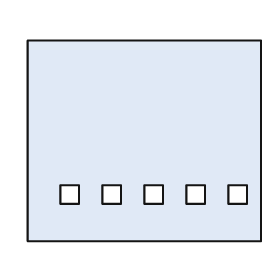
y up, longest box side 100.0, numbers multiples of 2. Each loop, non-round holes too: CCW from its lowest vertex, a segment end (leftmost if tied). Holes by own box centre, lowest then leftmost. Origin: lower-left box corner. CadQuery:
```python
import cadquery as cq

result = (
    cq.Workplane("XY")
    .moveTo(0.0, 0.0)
    .lineTo(100.0, 0.0)
    .lineTo(100.0, 86.0)
    .lineTo(0.0, 86.0)
    .close()
    .moveTo(14.0, 16.0)
    .lineTo(22.0, 16.0)
    .lineTo(22.0, 24.0)
    .lineTo(14.0, 24.0)
    .close()
    .moveTo(32.0, 16.0)
    .lineTo(40.0, 16.0)
    .lineTo(40.0, 24.0)
    .lineTo(32.0, 24.0)
    .close()
    .moveTo(50.0, 16.0)
    .lineTo(58.0, 16.0)
    .lineTo(58.0, 24.0)
    .lineTo(50.0, 24.0)
    .close()
    .moveTo(68.0, 16.0)
    .lineTo(76.0, 16.0)
    .lineTo(76.0, 24.0)
    .lineTo(68.0, 24.0)
    .close()
    .moveTo(86.0, 16.0)
    .lineTo(94.0, 16.0)
    .lineTo(94.0, 24.0)
    .lineTo(86.0, 24.0)
    .close()
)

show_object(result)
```